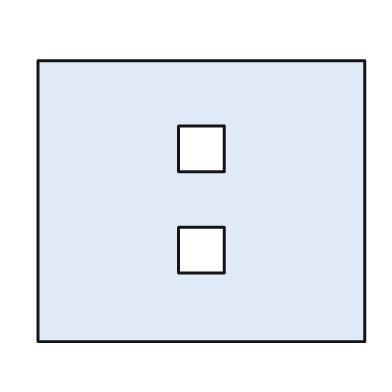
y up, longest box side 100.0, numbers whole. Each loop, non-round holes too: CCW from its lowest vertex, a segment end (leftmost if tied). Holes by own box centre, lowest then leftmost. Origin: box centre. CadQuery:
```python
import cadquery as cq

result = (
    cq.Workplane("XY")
    .moveTo(-50.0, -43.0)
    .lineTo(50.0, -43.0)
    .lineTo(50.0, 43.0)
    .lineTo(-50.0, 43.0)
    .close()
    .moveTo(-7.0, -22.0)
    .lineTo(7.0, -22.0)
    .lineTo(7.0, -8.0)
    .lineTo(-7.0, -8.0)
    .close()
    .moveTo(-7.0, 9.0)
    .lineTo(7.0, 9.0)
    .lineTo(7.0, 23.0)
    .lineTo(-7.0, 23.0)
    .close()
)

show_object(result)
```